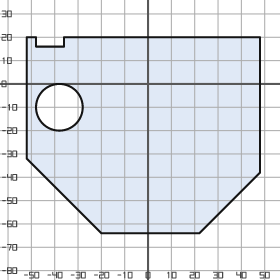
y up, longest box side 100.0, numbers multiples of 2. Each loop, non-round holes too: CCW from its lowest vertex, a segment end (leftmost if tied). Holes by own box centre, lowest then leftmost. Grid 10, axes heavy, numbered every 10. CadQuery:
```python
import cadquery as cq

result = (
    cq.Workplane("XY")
    .moveTo(-20.0, -64.0)
    .lineTo(22.0, -64.0)
    .lineTo(48.0, -38.0)
    .lineTo(48.0, 20.0)
    .lineTo(-36.0, 20.0)
    .lineTo(-36.0, 16.0)
    .lineTo(-48.0, 16.0)
    .lineTo(-48.0, 20.0)
    .lineTo(-52.0, 20.0)
    .lineTo(-52.0, -32.0)
    .close()
    .moveTo(-38.0, -10.0)
    .circle(10.0)
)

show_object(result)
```